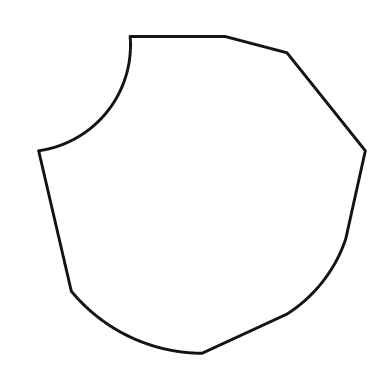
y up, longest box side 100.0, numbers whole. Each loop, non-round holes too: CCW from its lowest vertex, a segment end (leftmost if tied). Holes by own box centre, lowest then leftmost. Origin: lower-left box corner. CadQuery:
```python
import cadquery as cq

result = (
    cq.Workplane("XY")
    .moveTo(50.0, 0.0)
    .lineTo(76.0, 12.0)
    .threePointArc((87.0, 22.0), (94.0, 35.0))
    .lineTo(100.0, 62.0)
    .lineTo(76.0, 92.0)
    .lineTo(57.0, 97.0)
    .lineTo(28.0, 97.0)
    .threePointArc((21.0, 74.0), (0.0, 62.0))
    .lineTo(10.0, 19.0)
    .threePointArc((28.0, 5.0), (50.0, 0.0))
    .close()
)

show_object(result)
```